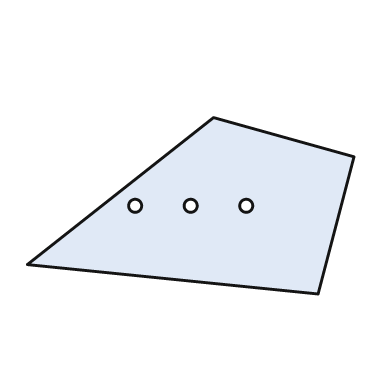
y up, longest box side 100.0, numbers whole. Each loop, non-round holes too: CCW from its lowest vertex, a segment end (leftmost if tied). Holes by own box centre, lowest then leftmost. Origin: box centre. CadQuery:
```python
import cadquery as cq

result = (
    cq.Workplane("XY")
    .moveTo(39.0, -27.0)
    .lineTo(50.0, 15.0)
    .lineTo(7.0, 27.0)
    .lineTo(-50.0, -18.0)
    .close()
    .moveTo(-17.0, 0.0)
    .circle(2.0)
    .moveTo(0.0, 0.0)
    .circle(2.0)
    .moveTo(17.0, 0.0)
    .circle(2.0)
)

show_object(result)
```